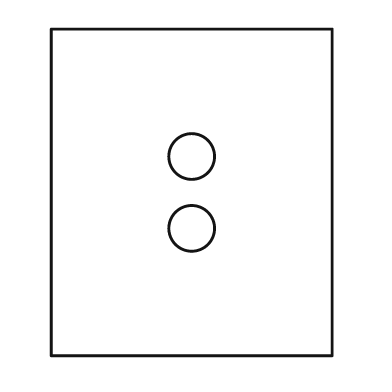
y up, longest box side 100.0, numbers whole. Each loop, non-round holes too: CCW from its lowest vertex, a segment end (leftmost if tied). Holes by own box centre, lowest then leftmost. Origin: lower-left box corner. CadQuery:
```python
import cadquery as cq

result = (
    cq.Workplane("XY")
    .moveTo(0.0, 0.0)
    .lineTo(86.0, 0.0)
    .lineTo(86.0, 100.0)
    .lineTo(0.0, 100.0)
    .close()
    .moveTo(43.0, 39.0)
    .circle(7.0)
    .moveTo(43.0, 61.0)
    .circle(7.0)
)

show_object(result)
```